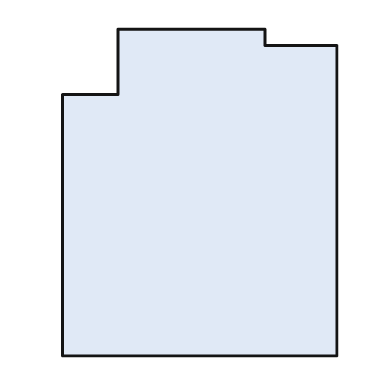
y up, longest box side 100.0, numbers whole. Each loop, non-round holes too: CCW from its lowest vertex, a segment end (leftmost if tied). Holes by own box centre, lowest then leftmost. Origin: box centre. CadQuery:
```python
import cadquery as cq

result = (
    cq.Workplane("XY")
    .moveTo(-42.0, -50.0)
    .lineTo(42.0, -50.0)
    .lineTo(42.0, 45.0)
    .lineTo(20.0, 45.0)
    .lineTo(20.0, 50.0)
    .lineTo(-25.0, 50.0)
    .lineTo(-25.0, 30.0)
    .lineTo(-42.0, 30.0)
    .close()
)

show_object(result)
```